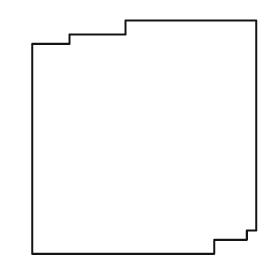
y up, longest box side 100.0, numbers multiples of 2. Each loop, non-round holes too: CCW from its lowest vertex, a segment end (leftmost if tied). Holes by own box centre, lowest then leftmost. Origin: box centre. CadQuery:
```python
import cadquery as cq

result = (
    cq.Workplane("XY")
    .moveTo(-48.0, -50.0)
    .lineTo(30.0, -50.0)
    .lineTo(30.0, -44.0)
    .lineTo(44.0, -44.0)
    .lineTo(44.0, -40.0)
    .lineTo(48.0, -40.0)
    .lineTo(48.0, 50.0)
    .lineTo(-8.0, 50.0)
    .lineTo(-8.0, 44.0)
    .lineTo(-32.0, 44.0)
    .lineTo(-32.0, 40.0)
    .lineTo(-48.0, 40.0)
    .close()
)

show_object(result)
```